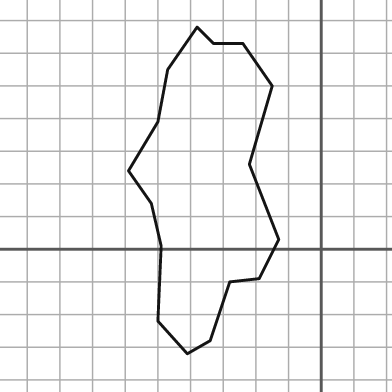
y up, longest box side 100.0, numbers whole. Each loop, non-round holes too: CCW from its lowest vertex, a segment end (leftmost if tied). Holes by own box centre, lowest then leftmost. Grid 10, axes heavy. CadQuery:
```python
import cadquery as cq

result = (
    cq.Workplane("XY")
    .moveTo(-41.0, -32.0)
    .lineTo(-34.0, -28.0)
    .lineTo(-28.0, -10.0)
    .lineTo(-19.0, -9.0)
    .lineTo(-13.0, 3.0)
    .lineTo(-22.0, 26.0)
    .lineTo(-15.0, 50.0)
    .lineTo(-24.0, 63.0)
    .lineTo(-33.0, 63.0)
    .lineTo(-38.0, 68.0)
    .lineTo(-47.0, 55.0)
    .lineTo(-50.0, 39.0)
    .lineTo(-59.0, 24.0)
    .lineTo(-52.0, 14.0)
    .lineTo(-49.0, 1.0)
    .lineTo(-50.0, -22.0)
    .close()
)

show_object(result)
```